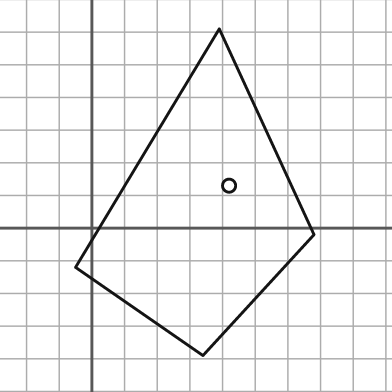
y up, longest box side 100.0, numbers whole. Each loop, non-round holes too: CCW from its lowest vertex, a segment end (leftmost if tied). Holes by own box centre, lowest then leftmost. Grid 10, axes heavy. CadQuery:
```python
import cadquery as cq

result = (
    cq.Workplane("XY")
    .moveTo(34.0, -39.0)
    .lineTo(68.0, -2.0)
    .lineTo(39.0, 61.0)
    .lineTo(-5.0, -12.0)
    .close()
    .moveTo(42.0, 13.0)
    .circle(2.0)
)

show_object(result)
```